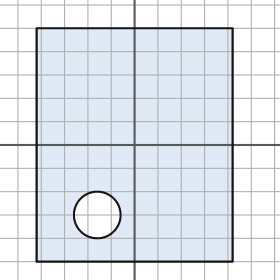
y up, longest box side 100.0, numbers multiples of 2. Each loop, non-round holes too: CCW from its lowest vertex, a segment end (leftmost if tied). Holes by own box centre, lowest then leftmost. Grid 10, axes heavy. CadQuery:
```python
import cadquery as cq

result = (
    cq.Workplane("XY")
    .moveTo(-42.0, -50.0)
    .lineTo(42.0, -50.0)
    .lineTo(42.0, 50.0)
    .lineTo(-42.0, 50.0)
    .close()
    .moveTo(-16.0, -30.0)
    .circle(10.0)
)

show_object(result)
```